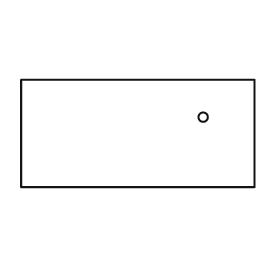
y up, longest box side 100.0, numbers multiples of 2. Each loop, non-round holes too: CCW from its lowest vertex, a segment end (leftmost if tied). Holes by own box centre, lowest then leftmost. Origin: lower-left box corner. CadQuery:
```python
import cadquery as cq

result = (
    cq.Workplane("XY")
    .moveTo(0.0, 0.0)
    .lineTo(100.0, 0.0)
    .lineTo(100.0, 46.0)
    .lineTo(0.0, 46.0)
    .close()
    .moveTo(78.0, 30.0)
    .circle(2.0)
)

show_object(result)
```